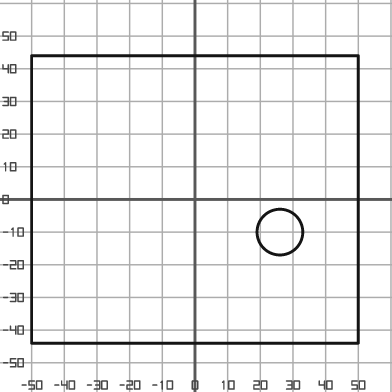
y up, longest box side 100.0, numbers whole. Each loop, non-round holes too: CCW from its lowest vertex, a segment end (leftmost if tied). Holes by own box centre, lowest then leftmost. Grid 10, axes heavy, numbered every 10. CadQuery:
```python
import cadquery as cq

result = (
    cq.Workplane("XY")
    .moveTo(-50.0, -44.0)
    .lineTo(50.0, -44.0)
    .lineTo(50.0, 44.0)
    .lineTo(-50.0, 44.0)
    .close()
    .moveTo(26.0, -10.0)
    .circle(7.0)
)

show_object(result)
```